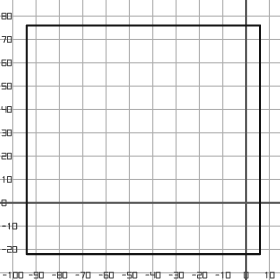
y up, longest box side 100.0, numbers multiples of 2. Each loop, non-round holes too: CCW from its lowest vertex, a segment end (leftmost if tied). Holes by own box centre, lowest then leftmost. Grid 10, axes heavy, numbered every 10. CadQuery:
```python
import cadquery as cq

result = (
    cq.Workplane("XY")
    .moveTo(-94.0, -22.0)
    .lineTo(6.0, -22.0)
    .lineTo(6.0, 76.0)
    .lineTo(-94.0, 76.0)
    .close()
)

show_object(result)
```